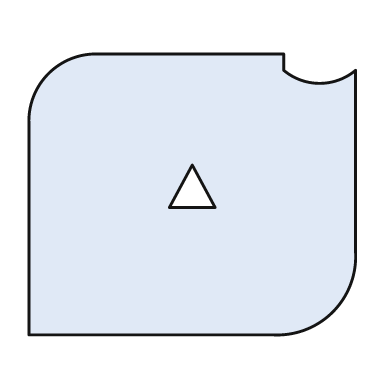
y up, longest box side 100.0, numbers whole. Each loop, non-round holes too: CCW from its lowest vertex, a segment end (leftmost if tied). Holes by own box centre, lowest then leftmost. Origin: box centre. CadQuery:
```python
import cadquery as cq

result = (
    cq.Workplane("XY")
    .moveTo(-50.0, -43.0)
    .lineTo(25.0, -43.0)
    .threePointArc((43.0, -36.0), (50.0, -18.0))
    .lineTo(50.0, 38.0)
    .threePointArc((39.0, 34.0), (28.0, 38.0))
    .lineTo(28.0, 43.0)
    .lineTo(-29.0, 43.0)
    .threePointArc((-44.0, 37.0), (-50.0, 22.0))
    .close()
    .moveTo(-7.0, -4.0)
    .lineTo(7.0, -4.0)
    .lineTo(0.0, 9.0)
    .close()
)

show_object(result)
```